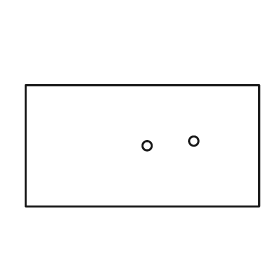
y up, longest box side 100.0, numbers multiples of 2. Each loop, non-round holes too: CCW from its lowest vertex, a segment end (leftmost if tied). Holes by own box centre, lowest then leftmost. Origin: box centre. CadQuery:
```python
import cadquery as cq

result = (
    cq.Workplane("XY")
    .moveTo(-50.0, -26.0)
    .lineTo(50.0, -26.0)
    .lineTo(50.0, 26.0)
    .lineTo(-50.0, 26.0)
    .close()
    .moveTo(2.0, 0.0)
    .circle(2.0)
    .moveTo(22.0, 2.0)
    .circle(2.0)
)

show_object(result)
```